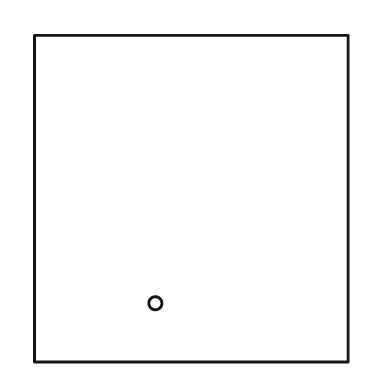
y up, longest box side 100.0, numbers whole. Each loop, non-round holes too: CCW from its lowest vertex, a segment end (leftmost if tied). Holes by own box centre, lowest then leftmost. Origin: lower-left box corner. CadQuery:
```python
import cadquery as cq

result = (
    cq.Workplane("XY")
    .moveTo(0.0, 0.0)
    .lineTo(96.0, 0.0)
    .lineTo(96.0, 100.0)
    .lineTo(0.0, 100.0)
    .close()
    .moveTo(37.0, 18.0)
    .circle(2.0)
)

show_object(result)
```